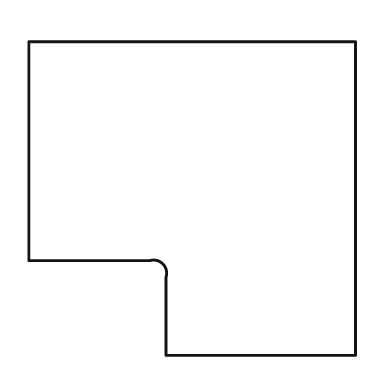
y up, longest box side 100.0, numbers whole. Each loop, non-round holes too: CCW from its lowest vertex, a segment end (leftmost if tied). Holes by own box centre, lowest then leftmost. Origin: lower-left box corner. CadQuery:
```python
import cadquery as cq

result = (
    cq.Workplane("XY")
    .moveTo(42.0, 0.0)
    .lineTo(100.0, 0.0)
    .lineTo(100.0, 96.0)
    .lineTo(0.0, 96.0)
    .lineTo(0.0, 29.0)
    .lineTo(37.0, 29.0)
    .threePointArc((41.0, 28.0), (42.0, 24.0))
    .close()
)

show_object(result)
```